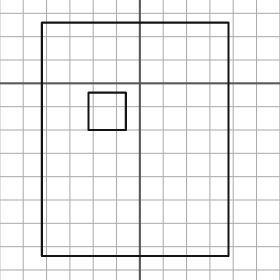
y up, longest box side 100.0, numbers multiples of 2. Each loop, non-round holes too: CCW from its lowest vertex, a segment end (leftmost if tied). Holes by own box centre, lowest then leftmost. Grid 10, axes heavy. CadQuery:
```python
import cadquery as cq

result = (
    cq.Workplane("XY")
    .moveTo(-42.0, -74.0)
    .lineTo(38.0, -74.0)
    .lineTo(38.0, 26.0)
    .lineTo(-42.0, 26.0)
    .close()
    .moveTo(-22.0, -20.0)
    .lineTo(-6.0, -20.0)
    .lineTo(-6.0, -4.0)
    .lineTo(-22.0, -4.0)
    .close()
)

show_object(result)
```